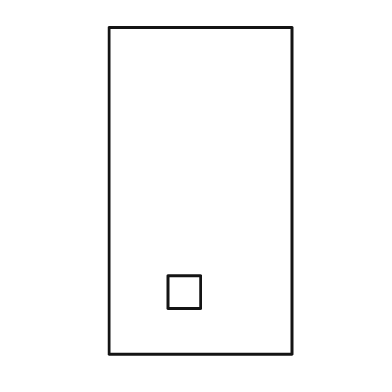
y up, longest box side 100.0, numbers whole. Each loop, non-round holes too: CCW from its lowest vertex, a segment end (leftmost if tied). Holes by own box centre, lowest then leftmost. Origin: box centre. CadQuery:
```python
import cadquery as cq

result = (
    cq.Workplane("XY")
    .moveTo(-28.0, -50.0)
    .lineTo(28.0, -50.0)
    .lineTo(28.0, 50.0)
    .lineTo(-28.0, 50.0)
    .close()
    .moveTo(-10.0, -36.0)
    .lineTo(0.0, -36.0)
    .lineTo(0.0, -26.0)
    .lineTo(-10.0, -26.0)
    .close()
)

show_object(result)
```